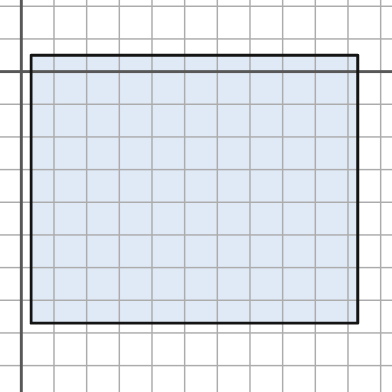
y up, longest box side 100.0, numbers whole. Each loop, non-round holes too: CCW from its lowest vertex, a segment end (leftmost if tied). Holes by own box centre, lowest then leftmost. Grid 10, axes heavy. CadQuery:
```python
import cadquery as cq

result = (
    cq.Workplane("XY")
    .moveTo(3.0, -77.0)
    .lineTo(103.0, -77.0)
    .lineTo(103.0, 5.0)
    .lineTo(3.0, 5.0)
    .close()
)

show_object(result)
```